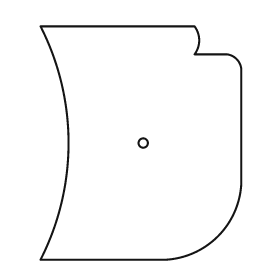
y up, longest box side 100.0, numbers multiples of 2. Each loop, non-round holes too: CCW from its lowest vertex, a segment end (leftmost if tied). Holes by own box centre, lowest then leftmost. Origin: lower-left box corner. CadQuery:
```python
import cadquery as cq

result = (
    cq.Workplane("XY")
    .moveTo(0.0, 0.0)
    .lineTo(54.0, 0.0)
    .threePointArc((76.0, 10.0), (86.0, 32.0))
    .lineTo(86.0, 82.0)
    .threePointArc((84.0, 86.0), (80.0, 88.0))
    .lineTo(66.0, 88.0)
    .threePointArc((68.0, 94.0), (66.0, 100.0))
    .lineTo(0.0, 100.0)
    .threePointArc((12.0, 50.0), (0.0, 0.0))
    .close()
    .moveTo(44.0, 50.0)
    .circle(2.0)
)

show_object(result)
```